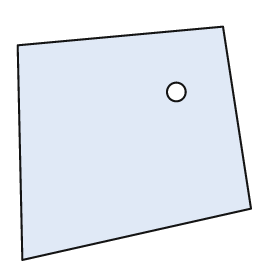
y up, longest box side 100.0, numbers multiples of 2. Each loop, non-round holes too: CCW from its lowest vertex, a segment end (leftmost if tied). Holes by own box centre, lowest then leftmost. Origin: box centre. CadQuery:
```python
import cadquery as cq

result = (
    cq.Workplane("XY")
    .moveTo(-48.0, -50.0)
    .lineTo(50.0, -28.0)
    .lineTo(38.0, 50.0)
    .lineTo(-50.0, 42.0)
    .close()
    .moveTo(18.0, 22.0)
    .circle(4.0)
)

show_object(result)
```